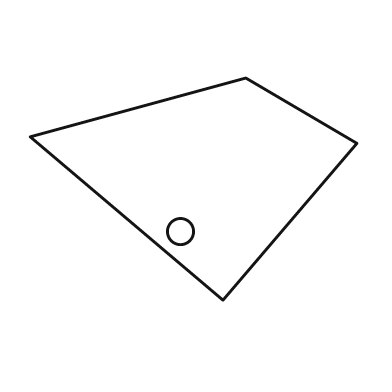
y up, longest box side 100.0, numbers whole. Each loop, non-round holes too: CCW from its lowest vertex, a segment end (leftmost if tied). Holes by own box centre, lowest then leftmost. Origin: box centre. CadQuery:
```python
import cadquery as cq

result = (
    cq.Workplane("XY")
    .moveTo(9.0, -34.0)
    .lineTo(50.0, 14.0)
    .lineTo(16.0, 34.0)
    .lineTo(-50.0, 16.0)
    .close()
    .moveTo(-4.0, -13.0)
    .circle(4.0)
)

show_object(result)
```